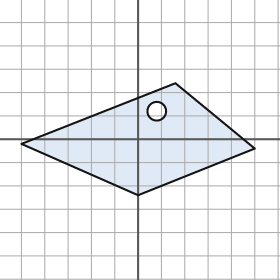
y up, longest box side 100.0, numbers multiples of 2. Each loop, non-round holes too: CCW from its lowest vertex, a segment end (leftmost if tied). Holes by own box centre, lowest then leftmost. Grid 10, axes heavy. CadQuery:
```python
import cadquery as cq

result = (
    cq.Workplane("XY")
    .moveTo(0.0, -24.0)
    .lineTo(50.0, -4.0)
    .lineTo(16.0, 24.0)
    .lineTo(-50.0, -2.0)
    .close()
    .moveTo(8.0, 12.0)
    .circle(4.0)
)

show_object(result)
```